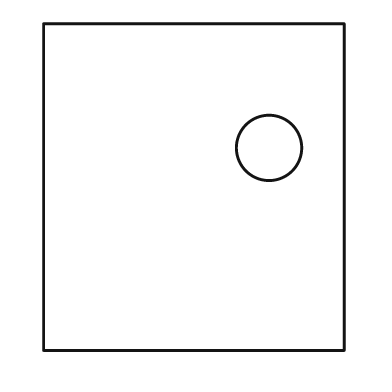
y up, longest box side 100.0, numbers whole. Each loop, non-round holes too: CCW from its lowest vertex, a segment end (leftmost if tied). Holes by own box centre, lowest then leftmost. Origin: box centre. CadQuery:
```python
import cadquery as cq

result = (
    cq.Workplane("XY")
    .moveTo(-46.0, -50.0)
    .lineTo(46.0, -50.0)
    .lineTo(46.0, 50.0)
    .lineTo(-46.0, 50.0)
    .close()
    .moveTo(23.0, 12.0)
    .circle(10.0)
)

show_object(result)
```